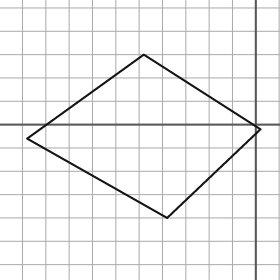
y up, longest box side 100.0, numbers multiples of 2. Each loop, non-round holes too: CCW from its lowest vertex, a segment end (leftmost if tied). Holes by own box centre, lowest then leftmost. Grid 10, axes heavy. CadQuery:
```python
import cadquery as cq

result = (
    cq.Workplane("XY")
    .moveTo(-38.0, -40.0)
    .lineTo(2.0, -2.0)
    .lineTo(-48.0, 30.0)
    .lineTo(-98.0, -6.0)
    .close()
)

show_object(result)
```